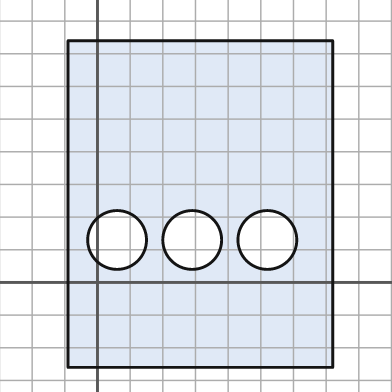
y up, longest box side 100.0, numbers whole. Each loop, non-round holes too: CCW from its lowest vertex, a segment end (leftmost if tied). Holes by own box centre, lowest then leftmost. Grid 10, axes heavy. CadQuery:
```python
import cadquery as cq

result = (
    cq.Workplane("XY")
    .moveTo(-9.0, -26.0)
    .lineTo(72.0, -26.0)
    .lineTo(72.0, 74.0)
    .lineTo(-9.0, 74.0)
    .close()
    .moveTo(6.0, 13.0)
    .circle(9.0)
    .moveTo(29.0, 13.0)
    .circle(9.0)
    .moveTo(52.0, 13.0)
    .circle(9.0)
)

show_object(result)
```